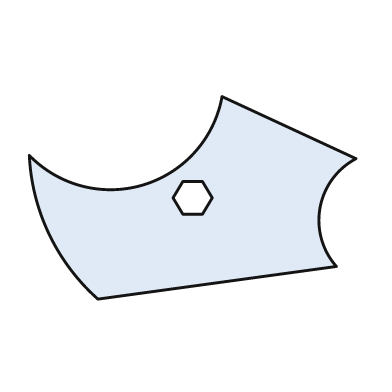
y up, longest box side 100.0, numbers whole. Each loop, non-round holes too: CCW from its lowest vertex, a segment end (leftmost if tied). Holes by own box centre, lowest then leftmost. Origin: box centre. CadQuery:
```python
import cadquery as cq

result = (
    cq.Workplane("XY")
    .moveTo(-29.0, -31.0)
    .lineTo(44.0, -21.0)
    .threePointArc((39.0, -3.0), (50.0, 12.0))
    .lineTo(9.0, 31.0)
    .threePointArc((-15.0, 4.0), (-50.0, 13.0))
    .threePointArc((-44.0, -11.0), (-29.0, -31.0))
    .close()
    .moveTo(-3.0, -5.0)
    .lineTo(3.0, -5.0)
    .lineTo(6.0, 0.0)
    .lineTo(3.0, 5.0)
    .lineTo(-3.0, 5.0)
    .lineTo(-6.0, 0.0)
    .close()
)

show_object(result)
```